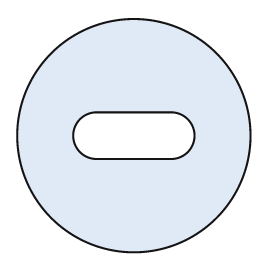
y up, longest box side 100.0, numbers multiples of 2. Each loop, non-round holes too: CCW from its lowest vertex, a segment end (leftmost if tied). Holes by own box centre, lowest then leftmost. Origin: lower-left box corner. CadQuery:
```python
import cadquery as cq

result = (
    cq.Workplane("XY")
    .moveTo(50.0, 50.0)
    .circle(50.0)
    .moveTo(34.0, 40.0)
    .lineTo(66.0, 40.0)
    .threePointArc((76.0, 50.0), (66.0, 60.0))
    .lineTo(34.0, 60.0)
    .threePointArc((24.0, 50.0), (34.0, 40.0))
    .close()
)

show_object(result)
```